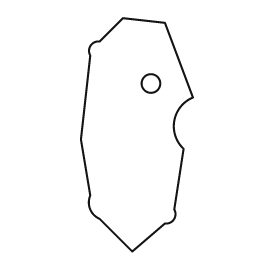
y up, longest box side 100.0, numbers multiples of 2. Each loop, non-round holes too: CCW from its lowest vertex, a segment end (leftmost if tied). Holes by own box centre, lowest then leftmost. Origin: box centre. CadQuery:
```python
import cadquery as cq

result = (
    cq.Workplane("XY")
    .moveTo(-2.0, -50.0)
    .lineTo(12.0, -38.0)
    .threePointArc((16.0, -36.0), (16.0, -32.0))
    .lineTo(20.0, -6.0)
    .threePointArc((16.0, 6.0), (24.0, 16.0))
    .lineTo(12.0, 48.0)
    .lineTo(-6.0, 50.0)
    .lineTo(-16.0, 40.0)
    .threePointArc((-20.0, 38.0), (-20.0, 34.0))
    .lineTo(-24.0, -2.0)
    .lineTo(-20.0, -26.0)
    .threePointArc((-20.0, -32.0), (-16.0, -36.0))
    .close()
    .moveTo(6.0, 22.0)
    .circle(4.0)
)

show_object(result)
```